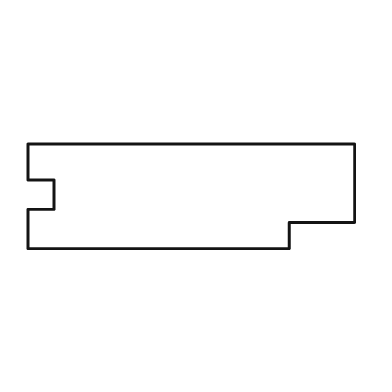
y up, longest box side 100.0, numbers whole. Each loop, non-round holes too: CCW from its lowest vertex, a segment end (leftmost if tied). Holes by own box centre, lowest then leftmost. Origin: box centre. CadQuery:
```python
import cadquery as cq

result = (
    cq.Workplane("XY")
    .moveTo(-50.0, -16.0)
    .lineTo(30.0, -16.0)
    .lineTo(30.0, -8.0)
    .lineTo(50.0, -8.0)
    .lineTo(50.0, 16.0)
    .lineTo(-50.0, 16.0)
    .lineTo(-50.0, 5.0)
    .lineTo(-42.0, 5.0)
    .lineTo(-42.0, -4.0)
    .lineTo(-50.0, -4.0)
    .close()
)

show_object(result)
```